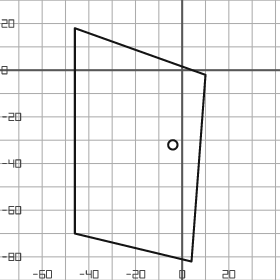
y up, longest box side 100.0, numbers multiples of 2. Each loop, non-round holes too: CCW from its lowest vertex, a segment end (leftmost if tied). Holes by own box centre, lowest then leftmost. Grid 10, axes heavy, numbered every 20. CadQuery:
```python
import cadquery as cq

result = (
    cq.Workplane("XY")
    .moveTo(4.0, -82.0)
    .lineTo(10.0, -2.0)
    .lineTo(-46.0, 18.0)
    .lineTo(-46.0, -70.0)
    .close()
    .moveTo(-4.0, -32.0)
    .circle(2.0)
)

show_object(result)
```